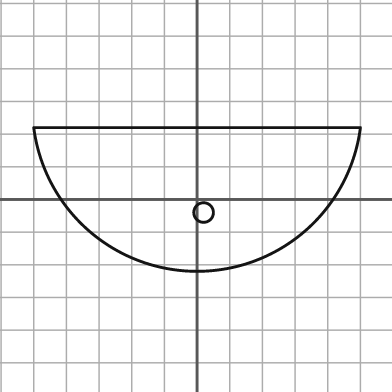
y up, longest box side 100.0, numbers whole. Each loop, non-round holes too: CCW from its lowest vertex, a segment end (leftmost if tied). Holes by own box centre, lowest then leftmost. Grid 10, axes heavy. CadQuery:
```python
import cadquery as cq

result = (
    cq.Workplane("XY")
    .moveTo(-50.0, 22.0)
    .threePointArc((0.0, -22.0), (50.0, 22.0))
    .close()
    .moveTo(2.0, -4.0)
    .circle(3.0)
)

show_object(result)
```